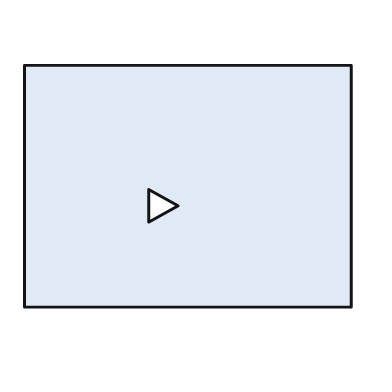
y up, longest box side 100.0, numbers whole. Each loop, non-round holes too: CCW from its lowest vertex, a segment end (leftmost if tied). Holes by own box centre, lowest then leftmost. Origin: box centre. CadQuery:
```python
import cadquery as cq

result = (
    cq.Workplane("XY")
    .moveTo(-50.0, -37.0)
    .lineTo(50.0, -37.0)
    .lineTo(50.0, 37.0)
    .lineTo(-50.0, 37.0)
    .close()
    .moveTo(-12.0, -11.0)
    .lineTo(-3.0, -6.0)
    .lineTo(-12.0, -1.0)
    .close()
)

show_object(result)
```